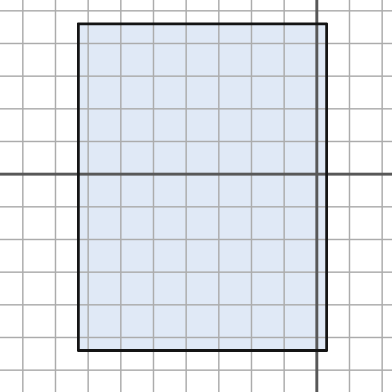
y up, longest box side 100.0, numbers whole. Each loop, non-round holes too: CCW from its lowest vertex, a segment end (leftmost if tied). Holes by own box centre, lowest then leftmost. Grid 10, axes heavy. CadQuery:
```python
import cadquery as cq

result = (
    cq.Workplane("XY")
    .moveTo(-73.0, -54.0)
    .lineTo(3.0, -54.0)
    .lineTo(3.0, 46.0)
    .lineTo(-73.0, 46.0)
    .close()
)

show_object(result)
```